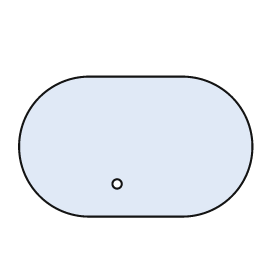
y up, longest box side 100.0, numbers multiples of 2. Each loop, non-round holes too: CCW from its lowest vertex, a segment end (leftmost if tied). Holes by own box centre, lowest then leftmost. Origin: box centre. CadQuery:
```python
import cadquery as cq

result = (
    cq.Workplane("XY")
    .moveTo(-20.0, -30.0)
    .lineTo(20.0, -30.0)
    .threePointArc((50.0, 0.0), (20.0, 30.0))
    .lineTo(-20.0, 30.0)
    .threePointArc((-50.0, 0.0), (-20.0, -30.0))
    .close()
    .moveTo(-8.0, -16.0)
    .circle(2.0)
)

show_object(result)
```